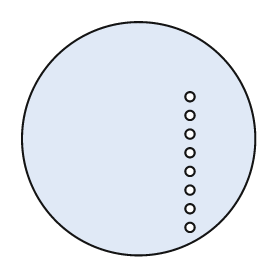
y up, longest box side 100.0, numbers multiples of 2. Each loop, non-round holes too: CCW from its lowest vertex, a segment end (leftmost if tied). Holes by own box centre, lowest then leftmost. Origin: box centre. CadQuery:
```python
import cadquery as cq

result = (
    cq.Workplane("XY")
    .moveTo(0.0, 0.0)
    .circle(50.0)
    .moveTo(22.0, -38.0)
    .circle(2.0)
    .moveTo(22.0, -30.0)
    .circle(2.0)
    .moveTo(22.0, -22.0)
    .circle(2.0)
    .moveTo(22.0, -14.0)
    .circle(2.0)
    .moveTo(22.0, -6.0)
    .circle(2.0)
    .moveTo(22.0, 2.0)
    .circle(2.0)
    .moveTo(22.0, 10.0)
    .circle(2.0)
    .moveTo(22.0, 18.0)
    .circle(2.0)
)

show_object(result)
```